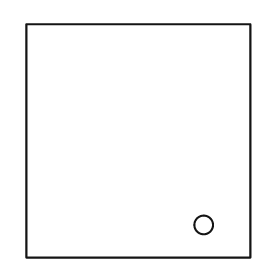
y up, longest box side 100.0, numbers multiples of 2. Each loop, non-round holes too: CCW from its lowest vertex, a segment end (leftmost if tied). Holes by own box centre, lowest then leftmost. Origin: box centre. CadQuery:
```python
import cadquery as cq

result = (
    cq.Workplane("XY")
    .moveTo(-48.0, -50.0)
    .lineTo(48.0, -50.0)
    .lineTo(48.0, 50.0)
    .lineTo(-48.0, 50.0)
    .close()
    .moveTo(28.0, -36.0)
    .circle(4.0)
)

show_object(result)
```